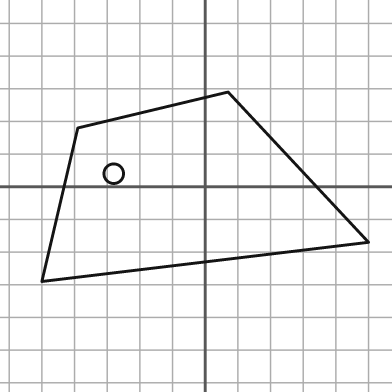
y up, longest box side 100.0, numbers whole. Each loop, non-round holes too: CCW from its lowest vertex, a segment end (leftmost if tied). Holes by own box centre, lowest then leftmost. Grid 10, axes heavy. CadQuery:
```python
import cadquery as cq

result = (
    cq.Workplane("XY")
    .moveTo(-50.0, -29.0)
    .lineTo(50.0, -17.0)
    .lineTo(7.0, 29.0)
    .lineTo(-39.0, 18.0)
    .close()
    .moveTo(-28.0, 4.0)
    .circle(3.0)
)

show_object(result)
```